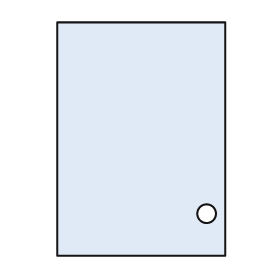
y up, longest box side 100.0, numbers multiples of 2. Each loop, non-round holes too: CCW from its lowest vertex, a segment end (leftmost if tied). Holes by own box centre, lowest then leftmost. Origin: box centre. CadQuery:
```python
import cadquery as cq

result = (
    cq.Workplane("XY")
    .moveTo(-36.0, -50.0)
    .lineTo(36.0, -50.0)
    .lineTo(36.0, 50.0)
    .lineTo(-36.0, 50.0)
    .close()
    .moveTo(28.0, -32.0)
    .circle(4.0)
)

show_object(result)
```